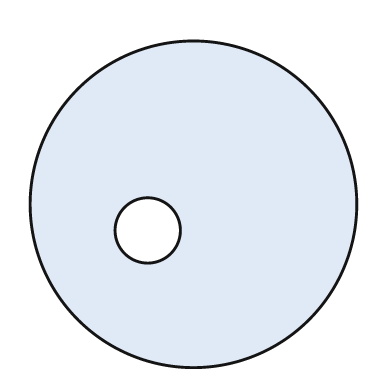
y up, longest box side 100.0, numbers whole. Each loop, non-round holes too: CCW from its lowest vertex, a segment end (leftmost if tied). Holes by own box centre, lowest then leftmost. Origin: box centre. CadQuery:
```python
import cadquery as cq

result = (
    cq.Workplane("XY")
    .moveTo(0.0, 0.0)
    .circle(50.0)
    .moveTo(-14.0, -8.0)
    .circle(10.0)
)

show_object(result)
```